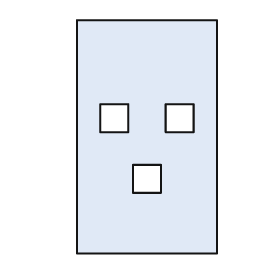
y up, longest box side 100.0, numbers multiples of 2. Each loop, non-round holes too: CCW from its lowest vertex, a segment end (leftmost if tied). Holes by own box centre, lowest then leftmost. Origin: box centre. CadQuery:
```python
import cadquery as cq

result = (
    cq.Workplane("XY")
    .moveTo(-30.0, -50.0)
    .lineTo(30.0, -50.0)
    .lineTo(30.0, 50.0)
    .lineTo(-30.0, 50.0)
    .close()
    .moveTo(-6.0, -24.0)
    .lineTo(6.0, -24.0)
    .lineTo(6.0, -12.0)
    .lineTo(-6.0, -12.0)
    .close()
    .moveTo(-20.0, 2.0)
    .lineTo(-8.0, 2.0)
    .lineTo(-8.0, 14.0)
    .lineTo(-20.0, 14.0)
    .close()
    .moveTo(8.0, 2.0)
    .lineTo(20.0, 2.0)
    .lineTo(20.0, 14.0)
    .lineTo(8.0, 14.0)
    .close()
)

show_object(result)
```